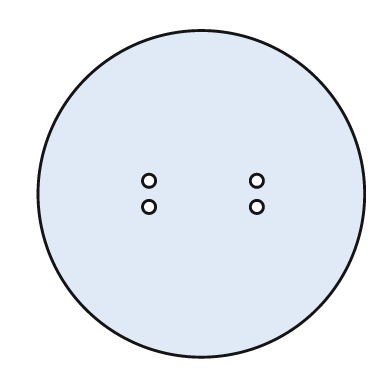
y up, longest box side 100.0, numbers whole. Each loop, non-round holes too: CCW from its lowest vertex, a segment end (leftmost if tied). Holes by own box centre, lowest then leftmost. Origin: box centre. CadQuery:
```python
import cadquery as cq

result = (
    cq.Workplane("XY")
    .moveTo(0.0, 0.0)
    .circle(50.0)
    .moveTo(-16.0, -4.0)
    .circle(2.0)
    .moveTo(17.0, -4.0)
    .circle(2.0)
    .moveTo(-16.0, 4.0)
    .circle(2.0)
    .moveTo(17.0, 4.0)
    .circle(2.0)
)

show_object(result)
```